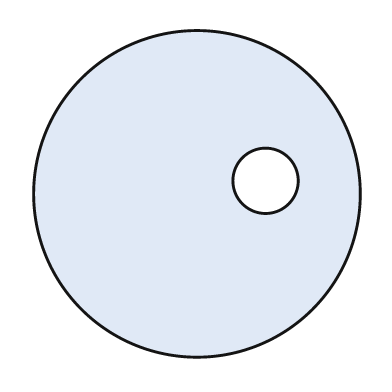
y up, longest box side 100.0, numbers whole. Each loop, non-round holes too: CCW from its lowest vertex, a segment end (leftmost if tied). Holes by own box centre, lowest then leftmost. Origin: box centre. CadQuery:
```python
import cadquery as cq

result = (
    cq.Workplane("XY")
    .moveTo(0.0, 0.0)
    .circle(50.0)
    .moveTo(21.0, 4.0)
    .circle(10.0)
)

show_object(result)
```